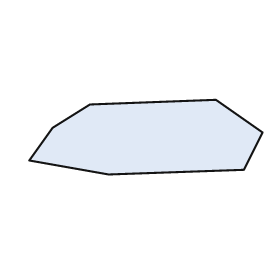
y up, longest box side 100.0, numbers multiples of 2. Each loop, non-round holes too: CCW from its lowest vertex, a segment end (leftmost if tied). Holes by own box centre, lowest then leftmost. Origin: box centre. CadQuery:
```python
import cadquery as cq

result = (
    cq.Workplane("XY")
    .moveTo(-16.0, -16.0)
    .lineTo(42.0, -14.0)
    .lineTo(50.0, 2.0)
    .lineTo(30.0, 16.0)
    .lineTo(-24.0, 14.0)
    .lineTo(-40.0, 4.0)
    .lineTo(-50.0, -10.0)
    .close()
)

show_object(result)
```